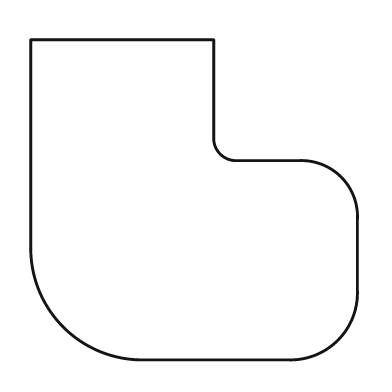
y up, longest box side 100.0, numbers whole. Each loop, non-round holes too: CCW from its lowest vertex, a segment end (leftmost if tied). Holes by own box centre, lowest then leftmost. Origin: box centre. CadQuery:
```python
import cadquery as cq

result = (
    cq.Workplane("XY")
    .moveTo(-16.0, -49.0)
    .lineTo(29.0, -49.0)
    .threePointArc((44.0, -43.0), (50.0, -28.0))
    .lineTo(50.0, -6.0)
    .threePointArc((45.0, 7.0), (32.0, 12.0))
    .lineTo(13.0, 12.0)
    .threePointArc((8.0, 14.0), (6.0, 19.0))
    .lineTo(6.0, 49.0)
    .lineTo(-50.0, 49.0)
    .lineTo(-50.0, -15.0)
    .threePointArc((-40.0, -39.0), (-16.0, -49.0))
    .close()
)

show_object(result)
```